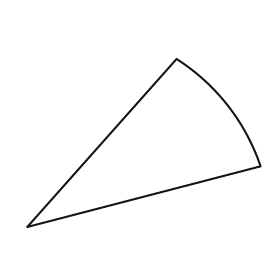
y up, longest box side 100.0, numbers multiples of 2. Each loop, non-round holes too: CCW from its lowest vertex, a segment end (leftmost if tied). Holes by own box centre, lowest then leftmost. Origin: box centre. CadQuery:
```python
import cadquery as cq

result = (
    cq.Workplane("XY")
    .moveTo(-50.0, -36.0)
    .lineTo(50.0, -10.0)
    .threePointArc((36.0, 16.0), (14.0, 36.0))
    .close()
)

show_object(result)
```